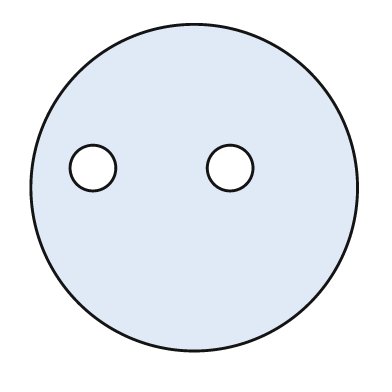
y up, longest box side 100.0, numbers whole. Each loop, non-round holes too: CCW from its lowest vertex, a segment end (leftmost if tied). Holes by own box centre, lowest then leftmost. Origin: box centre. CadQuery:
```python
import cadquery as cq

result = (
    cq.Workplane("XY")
    .moveTo(0.0, 0.0)
    .circle(50.0)
    .moveTo(-31.0, 6.0)
    .circle(7.0)
    .moveTo(11.0, 6.0)
    .circle(7.0)
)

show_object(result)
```